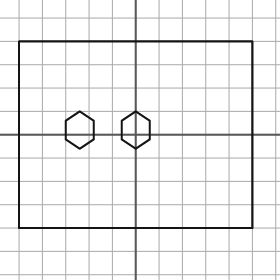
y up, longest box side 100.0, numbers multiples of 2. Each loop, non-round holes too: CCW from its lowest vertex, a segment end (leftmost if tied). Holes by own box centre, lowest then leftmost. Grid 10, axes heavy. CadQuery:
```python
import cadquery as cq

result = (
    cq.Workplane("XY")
    .moveTo(-50.0, -40.0)
    .lineTo(50.0, -40.0)
    .lineTo(50.0, 40.0)
    .lineTo(-50.0, 40.0)
    .close()
    .moveTo(-24.0, -6.0)
    .lineTo(-18.0, -2.0)
    .lineTo(-18.0, 6.0)
    .lineTo(-24.0, 10.0)
    .lineTo(-30.0, 6.0)
    .lineTo(-30.0, -2.0)
    .close()
    .moveTo(0.0, -6.0)
    .lineTo(6.0, -2.0)
    .lineTo(6.0, 6.0)
    .lineTo(0.0, 10.0)
    .lineTo(-6.0, 6.0)
    .lineTo(-6.0, -2.0)
    .close()
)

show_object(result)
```